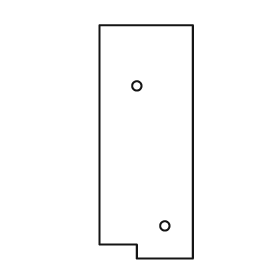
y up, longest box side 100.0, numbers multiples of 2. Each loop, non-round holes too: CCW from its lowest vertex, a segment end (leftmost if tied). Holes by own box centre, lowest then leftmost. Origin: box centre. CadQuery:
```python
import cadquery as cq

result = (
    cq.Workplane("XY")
    .moveTo(-4.0, -50.0)
    .lineTo(20.0, -50.0)
    .lineTo(20.0, 50.0)
    .lineTo(-20.0, 50.0)
    .lineTo(-20.0, -44.0)
    .lineTo(-4.0, -44.0)
    .close()
    .moveTo(8.0, -36.0)
    .circle(2.0)
    .moveTo(-4.0, 24.0)
    .circle(2.0)
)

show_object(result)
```